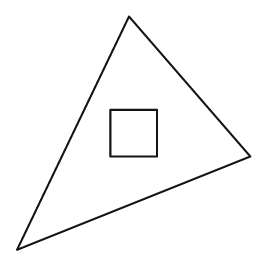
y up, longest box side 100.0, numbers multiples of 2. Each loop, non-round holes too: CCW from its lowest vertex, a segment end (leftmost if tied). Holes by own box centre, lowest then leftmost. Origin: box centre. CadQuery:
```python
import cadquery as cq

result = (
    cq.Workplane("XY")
    .moveTo(-50.0, -50.0)
    .lineTo(50.0, -10.0)
    .lineTo(-2.0, 50.0)
    .close()
    .moveTo(-10.0, -10.0)
    .lineTo(10.0, -10.0)
    .lineTo(10.0, 10.0)
    .lineTo(-10.0, 10.0)
    .close()
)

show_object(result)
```